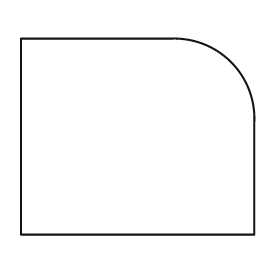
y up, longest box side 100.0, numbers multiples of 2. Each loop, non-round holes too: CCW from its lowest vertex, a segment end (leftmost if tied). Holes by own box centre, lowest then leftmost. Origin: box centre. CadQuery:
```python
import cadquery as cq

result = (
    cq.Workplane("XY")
    .moveTo(-50.0, -42.0)
    .lineTo(50.0, -42.0)
    .lineTo(50.0, 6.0)
    .threePointArc((40.0, 32.0), (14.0, 42.0))
    .lineTo(-50.0, 42.0)
    .close()
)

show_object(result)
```